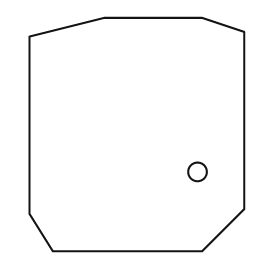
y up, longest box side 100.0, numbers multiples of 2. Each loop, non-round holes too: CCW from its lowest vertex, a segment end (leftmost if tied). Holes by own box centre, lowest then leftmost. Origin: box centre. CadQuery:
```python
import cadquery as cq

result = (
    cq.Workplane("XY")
    .moveTo(-36.0, -50.0)
    .lineTo(28.0, -50.0)
    .lineTo(46.0, -32.0)
    .lineTo(46.0, 44.0)
    .lineTo(28.0, 50.0)
    .lineTo(-14.0, 50.0)
    .lineTo(-46.0, 42.0)
    .lineTo(-46.0, -34.0)
    .close()
    .moveTo(26.0, -16.0)
    .circle(4.0)
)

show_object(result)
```